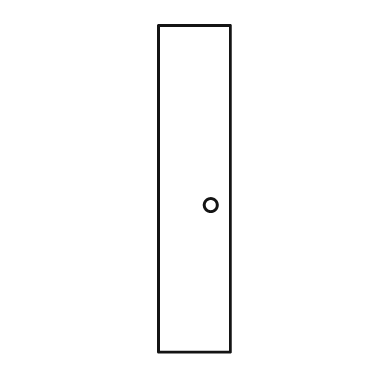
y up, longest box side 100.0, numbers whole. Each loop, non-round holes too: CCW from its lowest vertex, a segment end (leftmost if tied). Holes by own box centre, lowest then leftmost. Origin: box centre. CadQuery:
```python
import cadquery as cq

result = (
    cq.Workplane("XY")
    .moveTo(-11.0, -50.0)
    .lineTo(11.0, -50.0)
    .lineTo(11.0, 50.0)
    .lineTo(-11.0, 50.0)
    .close()
    .moveTo(5.0, -5.0)
    .circle(2.0)
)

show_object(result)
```